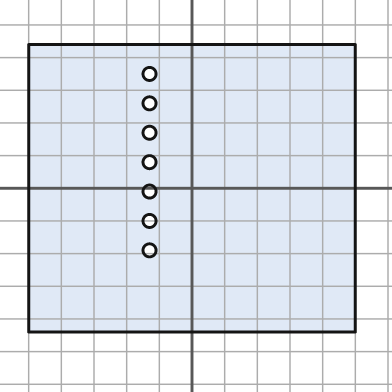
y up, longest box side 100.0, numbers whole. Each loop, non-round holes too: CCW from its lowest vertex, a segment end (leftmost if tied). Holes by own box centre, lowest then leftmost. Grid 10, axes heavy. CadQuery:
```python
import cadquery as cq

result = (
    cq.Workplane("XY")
    .moveTo(-50.0, -44.0)
    .lineTo(50.0, -44.0)
    .lineTo(50.0, 44.0)
    .lineTo(-50.0, 44.0)
    .close()
    .moveTo(-13.0, -19.0)
    .circle(2.0)
    .moveTo(-13.0, -10.0)
    .circle(2.0)
    .moveTo(-13.0, -1.0)
    .circle(2.0)
    .moveTo(-13.0, 8.0)
    .circle(2.0)
    .moveTo(-13.0, 17.0)
    .circle(2.0)
    .moveTo(-13.0, 26.0)
    .circle(2.0)
    .moveTo(-13.0, 35.0)
    .circle(2.0)
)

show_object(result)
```